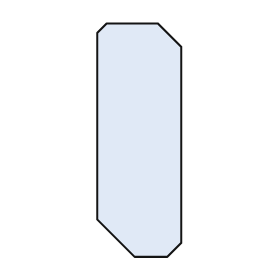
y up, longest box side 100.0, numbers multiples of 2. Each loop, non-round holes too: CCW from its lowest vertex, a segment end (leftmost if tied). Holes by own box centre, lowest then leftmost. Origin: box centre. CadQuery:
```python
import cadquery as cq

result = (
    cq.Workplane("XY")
    .moveTo(-2.0, -50.0)
    .lineTo(12.0, -50.0)
    .lineTo(18.0, -44.0)
    .lineTo(18.0, 40.0)
    .lineTo(8.0, 50.0)
    .lineTo(-14.0, 50.0)
    .lineTo(-18.0, 46.0)
    .lineTo(-18.0, -34.0)
    .close()
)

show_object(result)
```